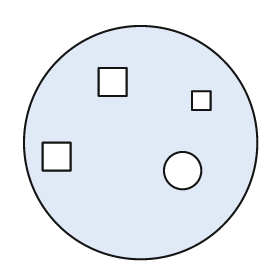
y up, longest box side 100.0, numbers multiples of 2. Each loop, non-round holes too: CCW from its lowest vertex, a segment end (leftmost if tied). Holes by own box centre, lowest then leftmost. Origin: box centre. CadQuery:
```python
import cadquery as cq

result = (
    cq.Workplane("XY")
    .moveTo(0.0, 0.0)
    .circle(50.0)
    .moveTo(18.0, -12.0)
    .circle(8.0)
    .moveTo(-42.0, -12.0)
    .lineTo(-30.0, -12.0)
    .lineTo(-30.0, 0.0)
    .lineTo(-42.0, 0.0)
    .close()
    .moveTo(22.0, 14.0)
    .lineTo(30.0, 14.0)
    .lineTo(30.0, 22.0)
    .lineTo(22.0, 22.0)
    .close()
    .moveTo(-18.0, 20.0)
    .lineTo(-6.0, 20.0)
    .lineTo(-6.0, 32.0)
    .lineTo(-18.0, 32.0)
    .close()
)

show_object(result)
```